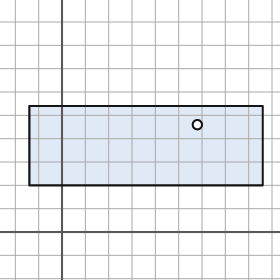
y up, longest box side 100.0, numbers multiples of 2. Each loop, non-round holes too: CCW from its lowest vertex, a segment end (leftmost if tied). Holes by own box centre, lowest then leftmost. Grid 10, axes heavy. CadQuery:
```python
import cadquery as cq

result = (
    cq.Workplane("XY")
    .moveTo(-14.0, 20.0)
    .lineTo(86.0, 20.0)
    .lineTo(86.0, 54.0)
    .lineTo(-14.0, 54.0)
    .close()
    .moveTo(58.0, 46.0)
    .circle(2.0)
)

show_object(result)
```